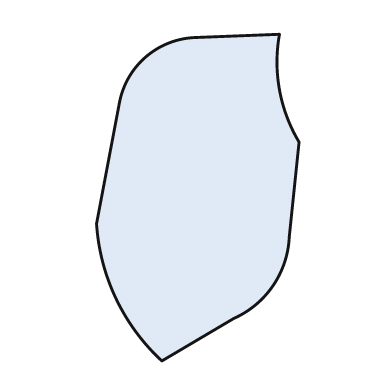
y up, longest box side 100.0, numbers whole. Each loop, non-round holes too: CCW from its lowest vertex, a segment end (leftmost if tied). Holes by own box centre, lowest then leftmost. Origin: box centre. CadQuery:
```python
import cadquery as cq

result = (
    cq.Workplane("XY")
    .moveTo(-11.0, -50.0)
    .lineTo(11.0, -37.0)
    .threePointArc((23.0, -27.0), (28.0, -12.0))
    .lineTo(31.0, 17.0)
    .threePointArc((25.0, 33.0), (25.0, 50.0))
    .lineTo(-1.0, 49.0)
    .threePointArc((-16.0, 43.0), (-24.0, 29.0))
    .lineTo(-31.0, -8.0)
    .threePointArc((-25.0, -31.0), (-11.0, -50.0))
    .close()
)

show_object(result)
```